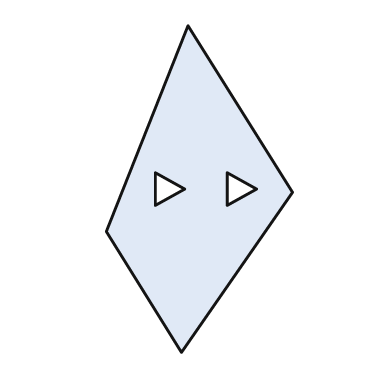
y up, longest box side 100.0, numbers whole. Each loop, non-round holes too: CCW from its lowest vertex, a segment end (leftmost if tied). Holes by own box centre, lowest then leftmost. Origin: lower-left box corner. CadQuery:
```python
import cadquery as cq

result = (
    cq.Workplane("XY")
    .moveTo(23.0, 0.0)
    .lineTo(57.0, 49.0)
    .lineTo(25.0, 100.0)
    .lineTo(0.0, 37.0)
    .close()
    .moveTo(15.0, 45.0)
    .lineTo(24.0, 50.0)
    .lineTo(15.0, 55.0)
    .close()
    .moveTo(37.0, 45.0)
    .lineTo(46.0, 50.0)
    .lineTo(37.0, 55.0)
    .close()
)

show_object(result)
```